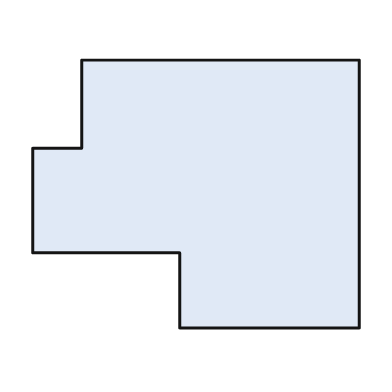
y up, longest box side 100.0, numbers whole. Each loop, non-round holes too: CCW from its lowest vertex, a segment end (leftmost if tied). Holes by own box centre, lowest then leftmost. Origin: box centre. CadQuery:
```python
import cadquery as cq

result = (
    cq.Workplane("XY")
    .moveTo(-5.0, -41.0)
    .lineTo(50.0, -41.0)
    .lineTo(50.0, 41.0)
    .lineTo(-35.0, 41.0)
    .lineTo(-35.0, 14.0)
    .lineTo(-50.0, 14.0)
    .lineTo(-50.0, -18.0)
    .lineTo(-5.0, -18.0)
    .close()
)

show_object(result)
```